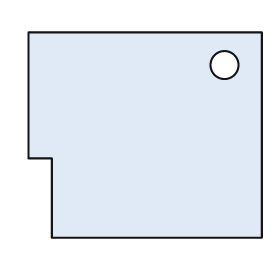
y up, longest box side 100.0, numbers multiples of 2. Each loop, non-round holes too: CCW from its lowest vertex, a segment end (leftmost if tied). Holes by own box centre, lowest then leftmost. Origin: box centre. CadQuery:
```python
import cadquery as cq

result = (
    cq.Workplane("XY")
    .moveTo(-40.0, -44.0)
    .lineTo(50.0, -44.0)
    .lineTo(50.0, 44.0)
    .lineTo(-50.0, 44.0)
    .lineTo(-50.0, -10.0)
    .lineTo(-40.0, -10.0)
    .close()
    .moveTo(34.0, 30.0)
    .circle(6.0)
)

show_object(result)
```